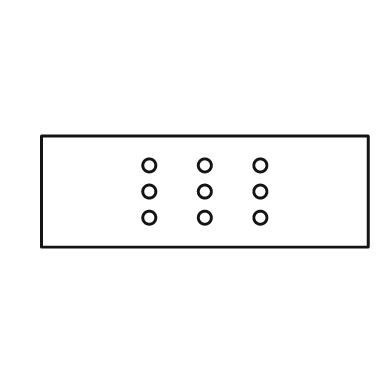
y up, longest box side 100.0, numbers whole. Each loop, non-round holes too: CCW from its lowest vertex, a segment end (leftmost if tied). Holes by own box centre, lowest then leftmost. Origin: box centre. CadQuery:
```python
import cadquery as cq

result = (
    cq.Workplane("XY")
    .moveTo(-50.0, -17.0)
    .lineTo(50.0, -17.0)
    .lineTo(50.0, 17.0)
    .lineTo(-50.0, 17.0)
    .close()
    .moveTo(-17.0, -8.0)
    .circle(2.0)
    .moveTo(0.0, -8.0)
    .circle(2.0)
    .moveTo(17.0, -8.0)
    .circle(2.0)
    .moveTo(-17.0, 0.0)
    .circle(2.0)
    .moveTo(0.0, 0.0)
    .circle(2.0)
    .moveTo(17.0, 0.0)
    .circle(2.0)
    .moveTo(-17.0, 8.0)
    .circle(2.0)
    .moveTo(0.0, 8.0)
    .circle(2.0)
    .moveTo(17.0, 8.0)
    .circle(2.0)
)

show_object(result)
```